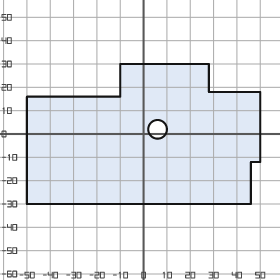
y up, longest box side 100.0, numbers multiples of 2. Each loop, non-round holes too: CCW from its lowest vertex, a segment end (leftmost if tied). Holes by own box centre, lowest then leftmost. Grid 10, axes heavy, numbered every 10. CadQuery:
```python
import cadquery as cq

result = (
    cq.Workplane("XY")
    .moveTo(-50.0, -30.0)
    .lineTo(46.0, -30.0)
    .lineTo(46.0, -12.0)
    .lineTo(50.0, -12.0)
    .lineTo(50.0, 18.0)
    .lineTo(28.0, 18.0)
    .lineTo(28.0, 30.0)
    .lineTo(-10.0, 30.0)
    .lineTo(-10.0, 16.0)
    .lineTo(-50.0, 16.0)
    .close()
    .moveTo(6.0, 2.0)
    .circle(4.0)
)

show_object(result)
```